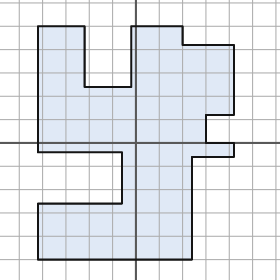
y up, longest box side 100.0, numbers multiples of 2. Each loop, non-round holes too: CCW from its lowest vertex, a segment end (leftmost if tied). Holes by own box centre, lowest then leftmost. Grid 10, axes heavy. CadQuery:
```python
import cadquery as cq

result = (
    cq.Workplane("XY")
    .moveTo(-42.0, -50.0)
    .lineTo(24.0, -50.0)
    .lineTo(24.0, -6.0)
    .lineTo(42.0, -6.0)
    .lineTo(42.0, 0.0)
    .lineTo(30.0, 0.0)
    .lineTo(30.0, 12.0)
    .lineTo(42.0, 12.0)
    .lineTo(42.0, 42.0)
    .lineTo(20.0, 42.0)
    .lineTo(20.0, 50.0)
    .lineTo(-2.0, 50.0)
    .lineTo(-2.0, 24.0)
    .lineTo(-22.0, 24.0)
    .lineTo(-22.0, 50.0)
    .lineTo(-42.0, 50.0)
    .lineTo(-42.0, -4.0)
    .lineTo(-6.0, -4.0)
    .lineTo(-6.0, -26.0)
    .lineTo(-42.0, -26.0)
    .close()
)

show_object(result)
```